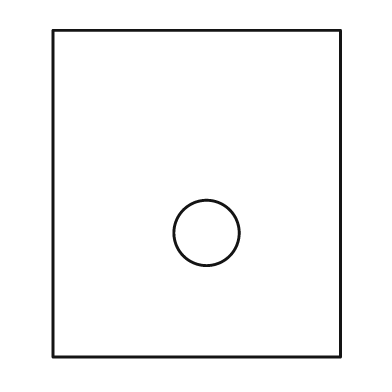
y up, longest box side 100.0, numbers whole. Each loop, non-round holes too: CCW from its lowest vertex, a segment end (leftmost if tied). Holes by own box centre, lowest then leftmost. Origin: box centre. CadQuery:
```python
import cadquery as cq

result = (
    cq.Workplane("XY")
    .moveTo(-44.0, -50.0)
    .lineTo(44.0, -50.0)
    .lineTo(44.0, 50.0)
    .lineTo(-44.0, 50.0)
    .close()
    .moveTo(3.0, -12.0)
    .circle(10.0)
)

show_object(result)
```